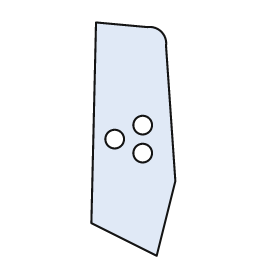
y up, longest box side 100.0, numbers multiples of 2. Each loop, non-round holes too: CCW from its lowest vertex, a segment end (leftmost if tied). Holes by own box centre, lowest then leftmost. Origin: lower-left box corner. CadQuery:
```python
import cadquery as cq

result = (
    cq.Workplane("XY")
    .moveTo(28.0, 0.0)
    .lineTo(36.0, 32.0)
    .lineTo(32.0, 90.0)
    .threePointArc((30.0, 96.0), (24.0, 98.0))
    .lineTo(2.0, 100.0)
    .lineTo(0.0, 14.0)
    .close()
    .moveTo(22.0, 44.0)
    .circle(4.0)
    .moveTo(10.0, 50.0)
    .circle(4.0)
    .moveTo(22.0, 56.0)
    .circle(4.0)
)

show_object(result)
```